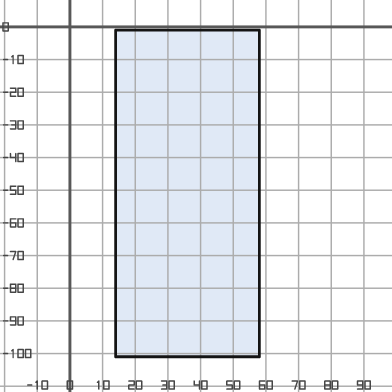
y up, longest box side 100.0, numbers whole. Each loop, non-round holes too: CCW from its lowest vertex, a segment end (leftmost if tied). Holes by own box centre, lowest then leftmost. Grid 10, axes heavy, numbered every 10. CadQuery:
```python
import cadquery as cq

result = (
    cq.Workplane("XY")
    .moveTo(14.0, -101.0)
    .lineTo(58.0, -101.0)
    .lineTo(58.0, -1.0)
    .lineTo(14.0, -1.0)
    .close()
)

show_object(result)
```